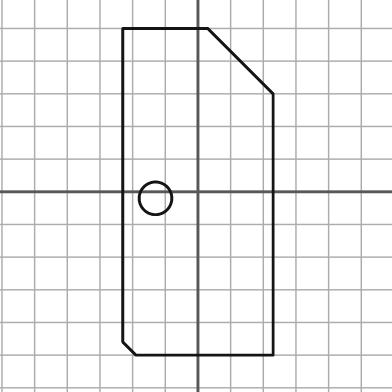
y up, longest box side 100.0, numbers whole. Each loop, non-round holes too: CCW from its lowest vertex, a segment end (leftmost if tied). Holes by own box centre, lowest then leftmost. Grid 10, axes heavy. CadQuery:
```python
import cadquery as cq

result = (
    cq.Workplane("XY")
    .moveTo(-19.0, -50.0)
    .lineTo(23.0, -50.0)
    .lineTo(23.0, 30.0)
    .lineTo(3.0, 50.0)
    .lineTo(-23.0, 50.0)
    .lineTo(-23.0, -46.0)
    .close()
    .moveTo(-13.0, -2.0)
    .circle(5.0)
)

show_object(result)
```